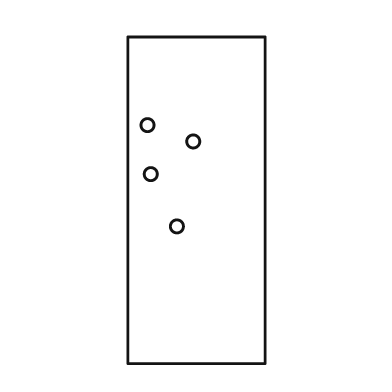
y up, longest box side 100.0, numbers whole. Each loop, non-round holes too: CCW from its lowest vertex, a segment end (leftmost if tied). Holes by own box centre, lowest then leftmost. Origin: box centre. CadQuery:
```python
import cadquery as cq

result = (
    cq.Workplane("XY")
    .moveTo(-21.0, -50.0)
    .lineTo(21.0, -50.0)
    .lineTo(21.0, 50.0)
    .lineTo(-21.0, 50.0)
    .close()
    .moveTo(-6.0, -8.0)
    .circle(2.0)
    .moveTo(-14.0, 8.0)
    .circle(2.0)
    .moveTo(-1.0, 18.0)
    .circle(2.0)
    .moveTo(-15.0, 23.0)
    .circle(2.0)
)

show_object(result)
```